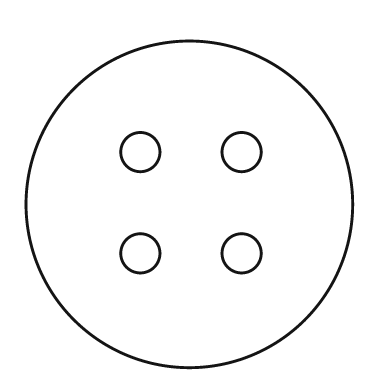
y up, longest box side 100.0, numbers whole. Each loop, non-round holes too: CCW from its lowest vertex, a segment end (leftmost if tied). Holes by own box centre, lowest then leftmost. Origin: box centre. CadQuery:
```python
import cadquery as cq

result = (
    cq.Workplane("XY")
    .moveTo(0.0, 0.0)
    .circle(50.0)
    .moveTo(-15.0, -15.0)
    .circle(6.0)
    .moveTo(16.0, -15.0)
    .circle(6.0)
    .moveTo(-15.0, 16.0)
    .circle(6.0)
    .moveTo(16.0, 16.0)
    .circle(6.0)
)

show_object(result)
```